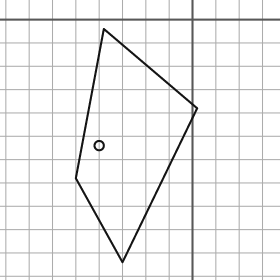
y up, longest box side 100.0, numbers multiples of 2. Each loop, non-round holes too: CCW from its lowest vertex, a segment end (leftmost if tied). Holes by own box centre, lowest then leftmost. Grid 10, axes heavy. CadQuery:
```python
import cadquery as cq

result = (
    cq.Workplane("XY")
    .moveTo(-30.0, -104.0)
    .lineTo(2.0, -38.0)
    .lineTo(-38.0, -4.0)
    .lineTo(-50.0, -68.0)
    .close()
    .moveTo(-40.0, -54.0)
    .circle(2.0)
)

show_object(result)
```